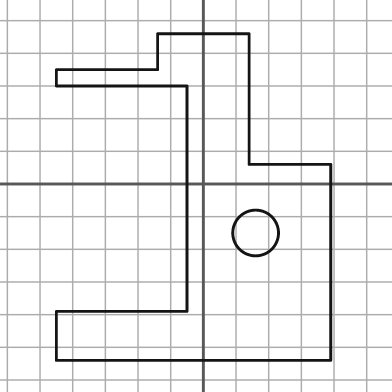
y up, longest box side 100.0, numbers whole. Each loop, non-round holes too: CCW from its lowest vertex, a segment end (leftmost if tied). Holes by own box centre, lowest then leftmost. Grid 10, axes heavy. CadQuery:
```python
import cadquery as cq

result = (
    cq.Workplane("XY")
    .moveTo(-45.0, -54.0)
    .lineTo(39.0, -54.0)
    .lineTo(39.0, 6.0)
    .lineTo(14.0, 6.0)
    .lineTo(14.0, 46.0)
    .lineTo(-14.0, 46.0)
    .lineTo(-14.0, 35.0)
    .lineTo(-45.0, 35.0)
    .lineTo(-45.0, 30.0)
    .lineTo(-5.0, 30.0)
    .lineTo(-5.0, -39.0)
    .lineTo(-45.0, -39.0)
    .close()
    .moveTo(16.0, -15.0)
    .circle(7.0)
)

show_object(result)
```